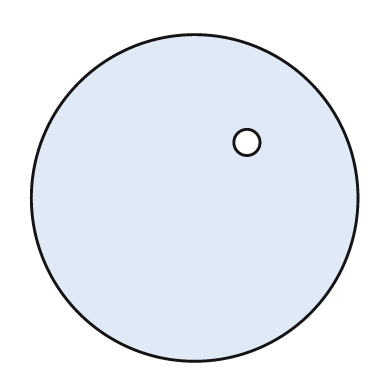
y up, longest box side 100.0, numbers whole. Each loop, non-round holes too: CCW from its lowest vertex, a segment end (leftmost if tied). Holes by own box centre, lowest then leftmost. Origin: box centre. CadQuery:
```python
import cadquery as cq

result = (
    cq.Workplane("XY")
    .moveTo(0.0, 0.0)
    .circle(50.0)
    .moveTo(16.0, 17.0)
    .circle(4.0)
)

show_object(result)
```